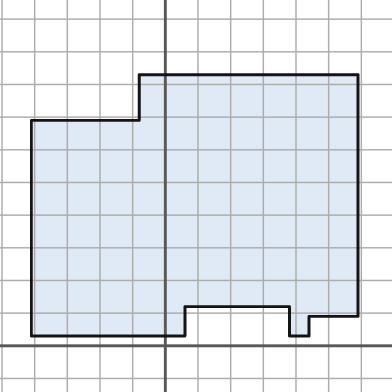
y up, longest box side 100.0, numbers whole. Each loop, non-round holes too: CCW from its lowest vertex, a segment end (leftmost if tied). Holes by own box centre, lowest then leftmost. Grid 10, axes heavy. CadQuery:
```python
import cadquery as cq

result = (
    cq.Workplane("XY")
    .moveTo(-41.0, 3.0)
    .lineTo(6.0, 3.0)
    .lineTo(6.0, 12.0)
    .lineTo(38.0, 12.0)
    .lineTo(38.0, 3.0)
    .lineTo(44.0, 3.0)
    .lineTo(44.0, 9.0)
    .lineTo(59.0, 9.0)
    .lineTo(59.0, 83.0)
    .lineTo(-8.0, 83.0)
    .lineTo(-8.0, 69.0)
    .lineTo(-41.0, 69.0)
    .close()
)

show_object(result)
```